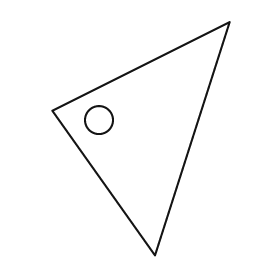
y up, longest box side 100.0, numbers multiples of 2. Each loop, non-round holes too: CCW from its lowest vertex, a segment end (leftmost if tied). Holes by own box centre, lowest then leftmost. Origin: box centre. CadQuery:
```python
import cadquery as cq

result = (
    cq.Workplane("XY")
    .moveTo(6.0, -50.0)
    .lineTo(38.0, 50.0)
    .lineTo(-38.0, 12.0)
    .close()
    .moveTo(-18.0, 8.0)
    .circle(6.0)
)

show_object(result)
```